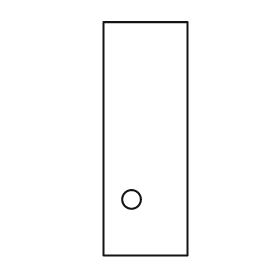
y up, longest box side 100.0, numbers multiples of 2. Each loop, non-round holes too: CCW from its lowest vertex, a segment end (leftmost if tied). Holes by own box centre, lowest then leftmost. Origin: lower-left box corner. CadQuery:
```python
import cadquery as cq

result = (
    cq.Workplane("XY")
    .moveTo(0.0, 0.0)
    .lineTo(36.0, 0.0)
    .lineTo(36.0, 100.0)
    .lineTo(0.0, 100.0)
    .close()
    .moveTo(12.0, 24.0)
    .circle(4.0)
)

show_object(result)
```